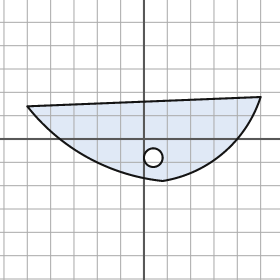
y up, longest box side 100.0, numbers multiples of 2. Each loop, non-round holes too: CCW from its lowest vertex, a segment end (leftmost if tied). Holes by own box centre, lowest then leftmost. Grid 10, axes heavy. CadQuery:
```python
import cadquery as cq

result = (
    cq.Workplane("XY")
    .moveTo(8.0, -18.0)
    .threePointArc((34.0, -6.0), (50.0, 18.0))
    .lineTo(-50.0, 14.0)
    .threePointArc((-24.0, -8.0), (8.0, -18.0))
    .close()
    .moveTo(4.0, -8.0)
    .circle(4.0)
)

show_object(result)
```